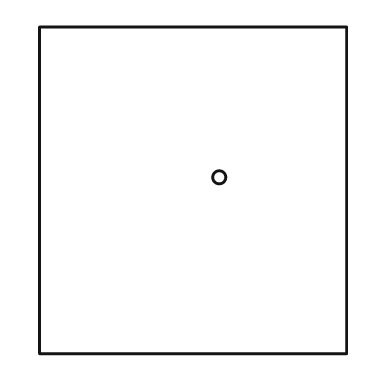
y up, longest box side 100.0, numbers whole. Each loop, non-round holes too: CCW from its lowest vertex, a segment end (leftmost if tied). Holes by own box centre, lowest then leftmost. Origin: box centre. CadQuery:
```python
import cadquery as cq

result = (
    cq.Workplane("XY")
    .moveTo(-47.0, -50.0)
    .lineTo(47.0, -50.0)
    .lineTo(47.0, 50.0)
    .lineTo(-47.0, 50.0)
    .close()
    .moveTo(8.0, 4.0)
    .circle(2.0)
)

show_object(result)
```